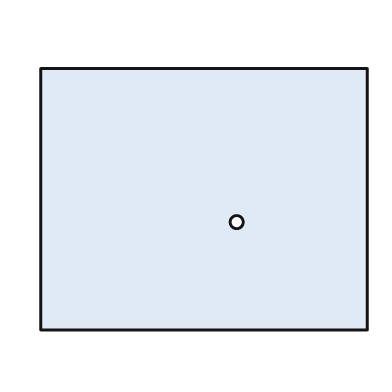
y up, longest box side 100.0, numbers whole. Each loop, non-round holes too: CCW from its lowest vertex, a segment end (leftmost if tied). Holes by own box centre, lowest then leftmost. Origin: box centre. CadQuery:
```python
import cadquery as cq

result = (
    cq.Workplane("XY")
    .moveTo(-50.0, -40.0)
    .lineTo(50.0, -40.0)
    .lineTo(50.0, 40.0)
    .lineTo(-50.0, 40.0)
    .close()
    .moveTo(10.0, -7.0)
    .circle(2.0)
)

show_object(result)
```